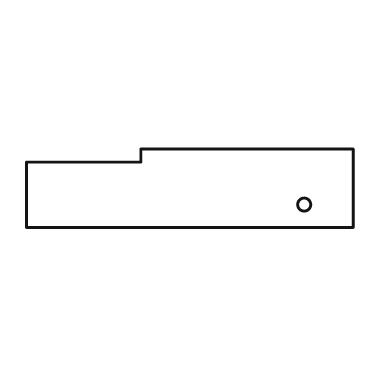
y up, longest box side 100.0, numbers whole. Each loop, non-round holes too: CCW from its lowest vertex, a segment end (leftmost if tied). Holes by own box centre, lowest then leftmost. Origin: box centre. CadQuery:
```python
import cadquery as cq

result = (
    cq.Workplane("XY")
    .moveTo(-50.0, -12.0)
    .lineTo(50.0, -12.0)
    .lineTo(50.0, 12.0)
    .lineTo(-15.0, 12.0)
    .lineTo(-15.0, 8.0)
    .lineTo(-50.0, 8.0)
    .close()
    .moveTo(35.0, -5.0)
    .circle(2.0)
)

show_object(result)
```